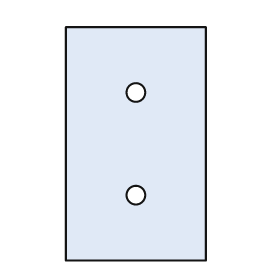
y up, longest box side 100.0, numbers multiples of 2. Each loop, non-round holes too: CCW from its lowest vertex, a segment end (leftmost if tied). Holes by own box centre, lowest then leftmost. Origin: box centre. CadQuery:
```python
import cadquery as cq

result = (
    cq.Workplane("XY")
    .moveTo(-30.0, -50.0)
    .lineTo(30.0, -50.0)
    .lineTo(30.0, 50.0)
    .lineTo(-30.0, 50.0)
    .close()
    .moveTo(0.0, -22.0)
    .circle(4.0)
    .moveTo(0.0, 22.0)
    .circle(4.0)
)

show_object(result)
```